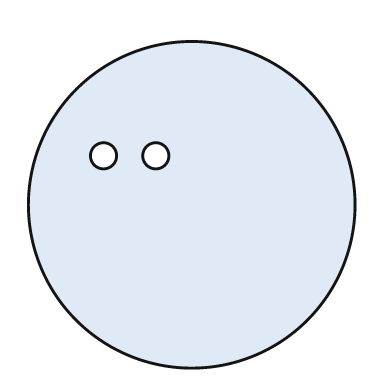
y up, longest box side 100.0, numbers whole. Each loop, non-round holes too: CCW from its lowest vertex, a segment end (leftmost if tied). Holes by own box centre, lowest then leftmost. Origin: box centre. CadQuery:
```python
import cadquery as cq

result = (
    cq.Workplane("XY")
    .moveTo(0.0, 0.0)
    .circle(50.0)
    .moveTo(-27.0, 15.0)
    .circle(4.0)
    .moveTo(-11.0, 15.0)
    .circle(4.0)
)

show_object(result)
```